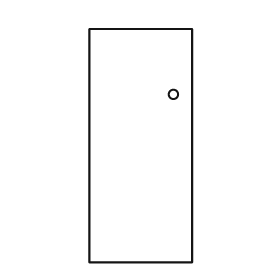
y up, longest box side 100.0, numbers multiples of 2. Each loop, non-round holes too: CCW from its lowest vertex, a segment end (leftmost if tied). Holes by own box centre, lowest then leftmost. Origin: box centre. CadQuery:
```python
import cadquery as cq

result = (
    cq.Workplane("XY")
    .moveTo(-22.0, -50.0)
    .lineTo(22.0, -50.0)
    .lineTo(22.0, 50.0)
    .lineTo(-22.0, 50.0)
    .close()
    .moveTo(14.0, 22.0)
    .circle(2.0)
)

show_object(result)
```